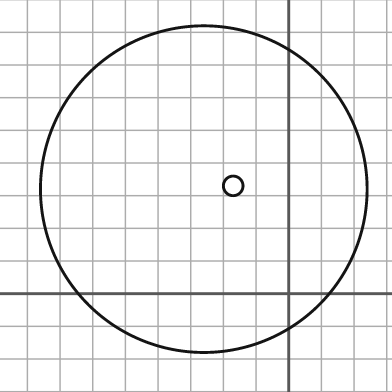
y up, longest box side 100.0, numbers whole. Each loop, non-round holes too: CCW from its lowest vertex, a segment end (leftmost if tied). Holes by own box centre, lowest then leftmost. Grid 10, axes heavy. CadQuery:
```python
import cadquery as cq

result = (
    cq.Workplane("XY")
    .moveTo(-26.0, 32.0)
    .circle(50.0)
    .moveTo(-17.0, 33.0)
    .circle(3.0)
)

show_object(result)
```